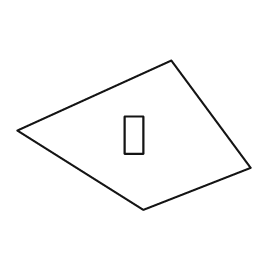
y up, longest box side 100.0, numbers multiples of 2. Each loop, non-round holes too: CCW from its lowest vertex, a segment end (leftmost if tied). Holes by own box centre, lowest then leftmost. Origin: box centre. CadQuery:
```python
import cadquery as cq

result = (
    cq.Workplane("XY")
    .moveTo(4.0, -32.0)
    .lineTo(50.0, -14.0)
    .lineTo(16.0, 32.0)
    .lineTo(-50.0, 2.0)
    .close()
    .moveTo(-4.0, -8.0)
    .lineTo(4.0, -8.0)
    .lineTo(4.0, 8.0)
    .lineTo(-4.0, 8.0)
    .close()
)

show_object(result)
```